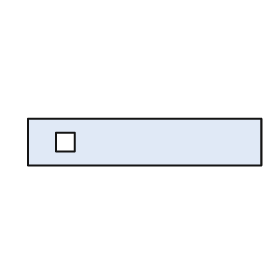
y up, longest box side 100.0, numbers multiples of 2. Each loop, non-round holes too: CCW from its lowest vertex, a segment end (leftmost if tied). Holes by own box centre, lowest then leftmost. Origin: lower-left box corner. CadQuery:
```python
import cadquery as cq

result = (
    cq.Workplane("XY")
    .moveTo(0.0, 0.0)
    .lineTo(100.0, 0.0)
    .lineTo(100.0, 20.0)
    .lineTo(0.0, 20.0)
    .close()
    .moveTo(12.0, 6.0)
    .lineTo(20.0, 6.0)
    .lineTo(20.0, 14.0)
    .lineTo(12.0, 14.0)
    .close()
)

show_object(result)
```